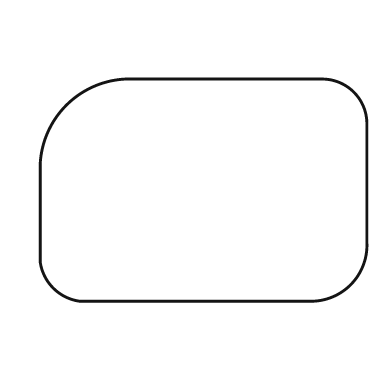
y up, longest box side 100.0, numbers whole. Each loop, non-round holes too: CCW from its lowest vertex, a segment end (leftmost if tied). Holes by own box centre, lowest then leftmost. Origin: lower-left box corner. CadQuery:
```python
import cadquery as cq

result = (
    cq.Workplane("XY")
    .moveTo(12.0, 0.0)
    .lineTo(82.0, 0.0)
    .threePointArc((95.0, 5.0), (100.0, 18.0))
    .lineTo(100.0, 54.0)
    .threePointArc((96.0, 64.0), (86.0, 68.0))
    .lineTo(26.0, 68.0)
    .threePointArc((8.0, 60.0), (0.0, 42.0))
    .lineTo(0.0, 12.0)
    .threePointArc((4.0, 4.0), (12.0, 0.0))
    .close()
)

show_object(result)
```